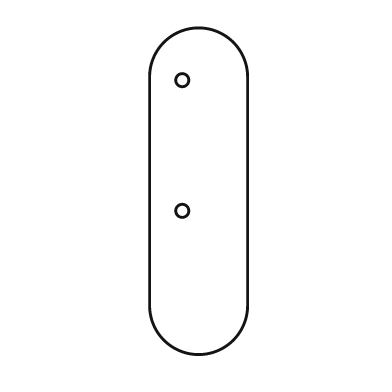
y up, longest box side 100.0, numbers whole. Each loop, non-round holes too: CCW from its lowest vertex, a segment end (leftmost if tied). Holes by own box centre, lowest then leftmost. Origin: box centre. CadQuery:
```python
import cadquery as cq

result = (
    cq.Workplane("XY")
    .moveTo(-15.0, -35.0)
    .threePointArc((0.0, -50.0), (15.0, -35.0))
    .lineTo(15.0, 35.0)
    .threePointArc((0.0, 50.0), (-15.0, 35.0))
    .close()
    .moveTo(-5.0, -6.0)
    .circle(2.0)
    .moveTo(-5.0, 34.0)
    .circle(2.0)
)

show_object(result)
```